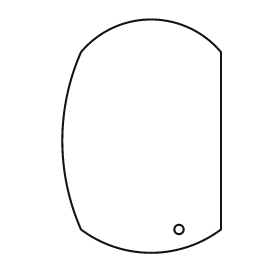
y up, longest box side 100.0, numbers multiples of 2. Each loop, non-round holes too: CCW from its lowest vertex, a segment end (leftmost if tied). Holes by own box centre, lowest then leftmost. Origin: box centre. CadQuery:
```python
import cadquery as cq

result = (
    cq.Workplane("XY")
    .moveTo(-26.0, -40.0)
    .threePointArc((4.0, -50.0), (34.0, -40.0))
    .lineTo(34.0, 36.0)
    .threePointArc((4.0, 50.0), (-26.0, 36.0))
    .threePointArc((-34.0, -2.0), (-26.0, -40.0))
    .close()
    .moveTo(16.0, -40.0)
    .circle(2.0)
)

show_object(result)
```